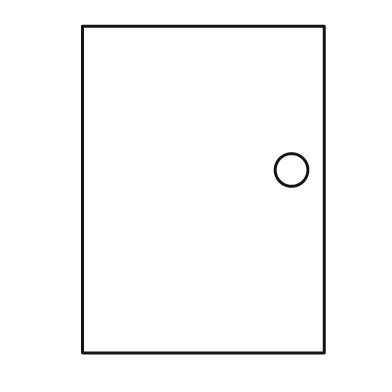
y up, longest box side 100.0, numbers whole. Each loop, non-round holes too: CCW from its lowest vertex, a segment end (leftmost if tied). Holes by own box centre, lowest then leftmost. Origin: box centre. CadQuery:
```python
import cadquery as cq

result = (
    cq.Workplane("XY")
    .moveTo(-37.0, -50.0)
    .lineTo(37.0, -50.0)
    .lineTo(37.0, 50.0)
    .lineTo(-37.0, 50.0)
    .close()
    .moveTo(27.0, 6.0)
    .circle(5.0)
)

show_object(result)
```